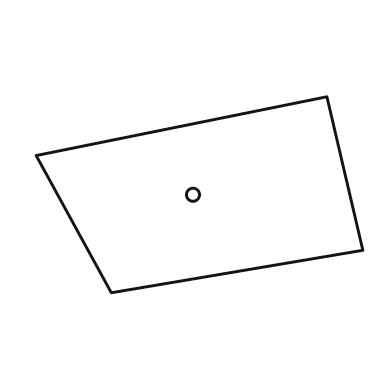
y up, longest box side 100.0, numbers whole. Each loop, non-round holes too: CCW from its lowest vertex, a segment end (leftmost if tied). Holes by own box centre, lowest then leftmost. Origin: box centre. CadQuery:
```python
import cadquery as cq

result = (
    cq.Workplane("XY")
    .moveTo(-27.0, -30.0)
    .lineTo(50.0, -17.0)
    .lineTo(39.0, 30.0)
    .lineTo(-50.0, 12.0)
    .close()
    .moveTo(-2.0, 0.0)
    .circle(2.0)
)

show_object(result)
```